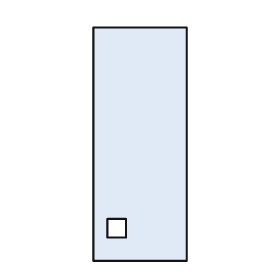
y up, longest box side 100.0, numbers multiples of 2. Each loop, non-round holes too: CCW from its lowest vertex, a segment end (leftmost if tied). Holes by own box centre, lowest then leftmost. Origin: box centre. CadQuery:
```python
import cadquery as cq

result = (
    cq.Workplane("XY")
    .moveTo(-20.0, -50.0)
    .lineTo(20.0, -50.0)
    .lineTo(20.0, 50.0)
    .lineTo(-20.0, 50.0)
    .close()
    .moveTo(-14.0, -40.0)
    .lineTo(-6.0, -40.0)
    .lineTo(-6.0, -32.0)
    .lineTo(-14.0, -32.0)
    .close()
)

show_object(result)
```